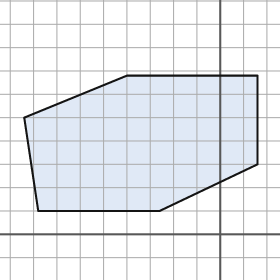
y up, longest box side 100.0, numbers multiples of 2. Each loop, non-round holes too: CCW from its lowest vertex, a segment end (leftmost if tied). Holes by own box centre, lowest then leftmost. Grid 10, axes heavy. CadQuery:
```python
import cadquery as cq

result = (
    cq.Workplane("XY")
    .moveTo(-78.0, 10.0)
    .lineTo(-26.0, 10.0)
    .lineTo(16.0, 30.0)
    .lineTo(16.0, 68.0)
    .lineTo(-40.0, 68.0)
    .lineTo(-84.0, 50.0)
    .close()
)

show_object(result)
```